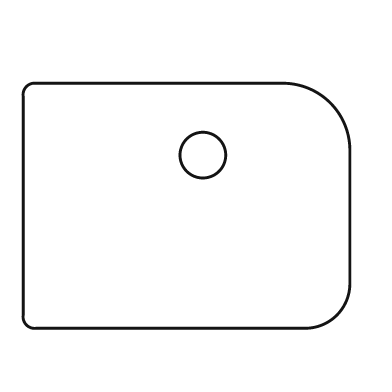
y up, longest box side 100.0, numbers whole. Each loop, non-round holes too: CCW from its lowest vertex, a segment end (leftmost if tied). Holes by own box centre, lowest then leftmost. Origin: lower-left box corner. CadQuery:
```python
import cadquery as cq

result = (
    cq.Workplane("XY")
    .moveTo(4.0, 0.0)
    .lineTo(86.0, 0.0)
    .threePointArc((96.0, 4.0), (100.0, 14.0))
    .lineTo(100.0, 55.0)
    .threePointArc((94.0, 69.0), (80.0, 75.0))
    .lineTo(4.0, 75.0)
    .threePointArc((1.0, 74.0), (0.0, 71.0))
    .lineTo(0.0, 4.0)
    .threePointArc((1.0, 1.0), (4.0, 0.0))
    .close()
    .moveTo(55.0, 53.0)
    .circle(7.0)
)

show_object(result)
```